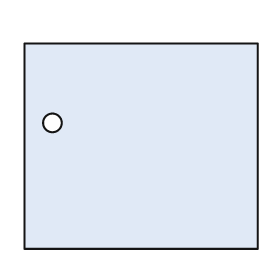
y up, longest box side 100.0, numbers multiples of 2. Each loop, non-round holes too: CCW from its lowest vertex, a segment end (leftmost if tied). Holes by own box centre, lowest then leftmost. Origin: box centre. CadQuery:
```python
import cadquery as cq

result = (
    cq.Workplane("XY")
    .moveTo(-50.0, -44.0)
    .lineTo(50.0, -44.0)
    .lineTo(50.0, 44.0)
    .lineTo(-50.0, 44.0)
    .close()
    .moveTo(-38.0, 10.0)
    .circle(4.0)
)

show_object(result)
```